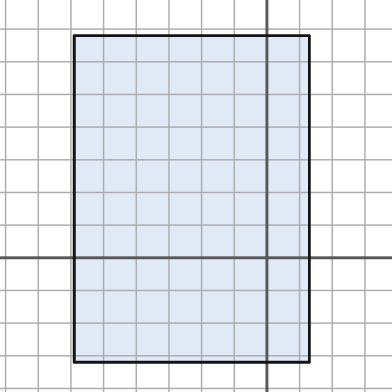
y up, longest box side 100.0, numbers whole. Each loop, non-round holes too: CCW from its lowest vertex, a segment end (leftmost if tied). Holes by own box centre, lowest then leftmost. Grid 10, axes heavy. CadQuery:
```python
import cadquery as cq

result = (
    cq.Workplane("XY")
    .moveTo(-59.0, -32.0)
    .lineTo(13.0, -32.0)
    .lineTo(13.0, 68.0)
    .lineTo(-59.0, 68.0)
    .close()
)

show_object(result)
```